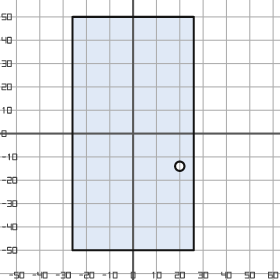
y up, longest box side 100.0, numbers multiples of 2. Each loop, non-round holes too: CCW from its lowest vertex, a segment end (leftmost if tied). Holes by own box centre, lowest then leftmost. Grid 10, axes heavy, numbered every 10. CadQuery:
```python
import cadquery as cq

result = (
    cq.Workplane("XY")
    .moveTo(-26.0, -50.0)
    .lineTo(26.0, -50.0)
    .lineTo(26.0, 50.0)
    .lineTo(-26.0, 50.0)
    .close()
    .moveTo(20.0, -14.0)
    .circle(2.0)
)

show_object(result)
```